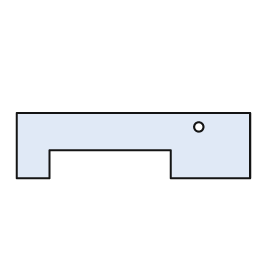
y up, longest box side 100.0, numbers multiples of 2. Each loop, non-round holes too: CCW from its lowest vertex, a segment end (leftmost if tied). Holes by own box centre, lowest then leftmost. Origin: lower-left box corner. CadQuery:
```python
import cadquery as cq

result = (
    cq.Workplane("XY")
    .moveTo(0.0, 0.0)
    .lineTo(14.0, 0.0)
    .lineTo(14.0, 12.0)
    .lineTo(66.0, 12.0)
    .lineTo(66.0, 0.0)
    .lineTo(100.0, 0.0)
    .lineTo(100.0, 28.0)
    .lineTo(0.0, 28.0)
    .close()
    .moveTo(78.0, 22.0)
    .circle(2.0)
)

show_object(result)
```